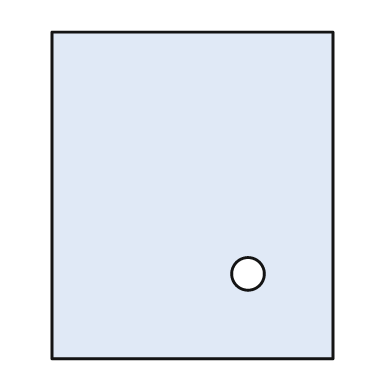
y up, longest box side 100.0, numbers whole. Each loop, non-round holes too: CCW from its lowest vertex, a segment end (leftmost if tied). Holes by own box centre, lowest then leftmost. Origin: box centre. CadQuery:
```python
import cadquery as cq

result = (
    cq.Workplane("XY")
    .moveTo(-43.0, -50.0)
    .lineTo(43.0, -50.0)
    .lineTo(43.0, 50.0)
    .lineTo(-43.0, 50.0)
    .close()
    .moveTo(17.0, -24.0)
    .circle(5.0)
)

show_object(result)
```